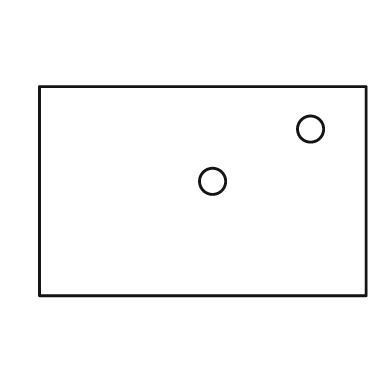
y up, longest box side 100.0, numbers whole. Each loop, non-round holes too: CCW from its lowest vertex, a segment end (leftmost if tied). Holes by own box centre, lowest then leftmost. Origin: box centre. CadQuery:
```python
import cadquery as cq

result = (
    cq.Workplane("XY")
    .moveTo(-50.0, -32.0)
    .lineTo(50.0, -32.0)
    .lineTo(50.0, 32.0)
    .lineTo(-50.0, 32.0)
    .close()
    .moveTo(3.0, 3.0)
    .circle(4.0)
    .moveTo(33.0, 19.0)
    .circle(4.0)
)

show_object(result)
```